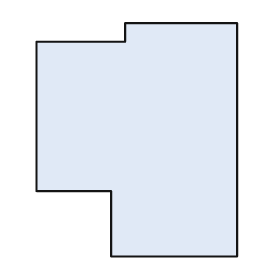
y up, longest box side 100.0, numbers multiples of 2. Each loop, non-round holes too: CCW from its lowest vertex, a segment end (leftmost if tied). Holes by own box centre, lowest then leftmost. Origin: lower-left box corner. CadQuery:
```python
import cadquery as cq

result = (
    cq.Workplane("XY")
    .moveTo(32.0, 0.0)
    .lineTo(86.0, 0.0)
    .lineTo(86.0, 100.0)
    .lineTo(38.0, 100.0)
    .lineTo(38.0, 92.0)
    .lineTo(0.0, 92.0)
    .lineTo(0.0, 28.0)
    .lineTo(32.0, 28.0)
    .close()
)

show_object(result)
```